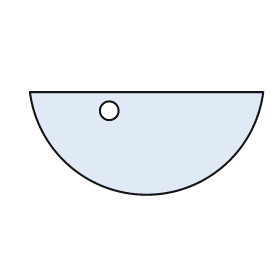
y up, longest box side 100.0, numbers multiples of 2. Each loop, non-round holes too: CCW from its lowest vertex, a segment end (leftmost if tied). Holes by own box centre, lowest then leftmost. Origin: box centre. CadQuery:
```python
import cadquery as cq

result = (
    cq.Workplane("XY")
    .moveTo(-50.0, 22.0)
    .threePointArc((0.0, -22.0), (50.0, 22.0))
    .close()
    .moveTo(-16.0, 14.0)
    .circle(4.0)
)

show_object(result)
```